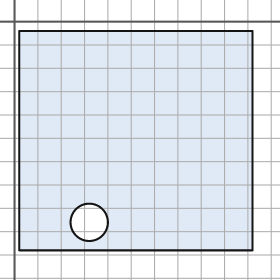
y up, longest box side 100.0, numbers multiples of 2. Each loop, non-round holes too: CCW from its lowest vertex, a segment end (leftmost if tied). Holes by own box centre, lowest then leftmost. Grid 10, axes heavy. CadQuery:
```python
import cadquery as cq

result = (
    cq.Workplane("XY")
    .moveTo(2.0, -98.0)
    .lineTo(102.0, -98.0)
    .lineTo(102.0, -4.0)
    .lineTo(2.0, -4.0)
    .close()
    .moveTo(32.0, -86.0)
    .circle(8.0)
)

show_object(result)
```